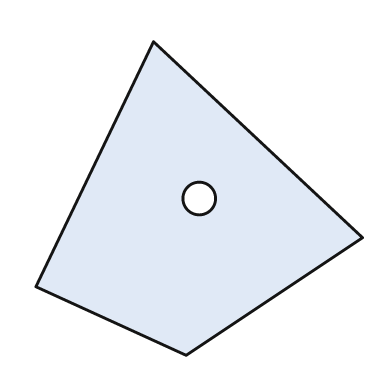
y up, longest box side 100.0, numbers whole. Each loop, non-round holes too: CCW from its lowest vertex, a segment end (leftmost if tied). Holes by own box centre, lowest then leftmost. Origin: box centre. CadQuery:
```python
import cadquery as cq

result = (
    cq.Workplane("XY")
    .moveTo(-4.0, -48.0)
    .lineTo(50.0, -12.0)
    .lineTo(-14.0, 48.0)
    .lineTo(-50.0, -27.0)
    .close()
    .moveTo(0.0, 0.0)
    .circle(5.0)
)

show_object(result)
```